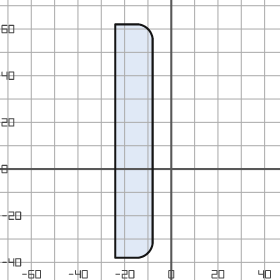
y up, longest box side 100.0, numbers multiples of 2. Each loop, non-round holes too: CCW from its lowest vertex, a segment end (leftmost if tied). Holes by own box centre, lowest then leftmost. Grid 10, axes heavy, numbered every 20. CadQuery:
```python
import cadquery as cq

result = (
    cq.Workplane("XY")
    .moveTo(-24.0, -38.0)
    .lineTo(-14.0, -38.0)
    .threePointArc((-10.0, -36.0), (-8.0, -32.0))
    .lineTo(-8.0, 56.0)
    .threePointArc((-10.0, 60.0), (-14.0, 62.0))
    .lineTo(-24.0, 62.0)
    .close()
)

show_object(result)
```